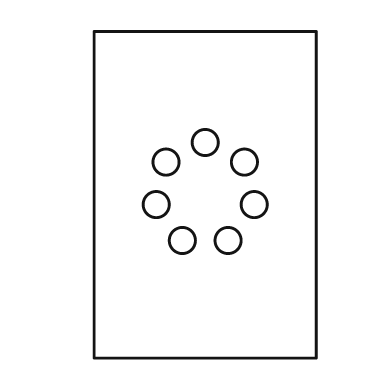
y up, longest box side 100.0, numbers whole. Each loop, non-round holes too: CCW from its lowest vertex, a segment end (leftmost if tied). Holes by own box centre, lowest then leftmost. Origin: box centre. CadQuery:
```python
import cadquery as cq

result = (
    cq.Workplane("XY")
    .moveTo(-34.0, -50.0)
    .lineTo(34.0, -50.0)
    .lineTo(34.0, 50.0)
    .lineTo(-34.0, 50.0)
    .close()
    .moveTo(-7.0, -14.0)
    .circle(4.0)
    .moveTo(7.0, -14.0)
    .circle(4.0)
    .moveTo(-15.0, -3.0)
    .circle(4.0)
    .moveTo(15.0, -3.0)
    .circle(4.0)
    .moveTo(-12.0, 10.0)
    .circle(4.0)
    .moveTo(12.0, 10.0)
    .circle(4.0)
    .moveTo(0.0, 16.0)
    .circle(4.0)
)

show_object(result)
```